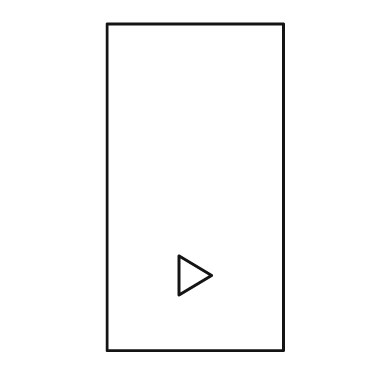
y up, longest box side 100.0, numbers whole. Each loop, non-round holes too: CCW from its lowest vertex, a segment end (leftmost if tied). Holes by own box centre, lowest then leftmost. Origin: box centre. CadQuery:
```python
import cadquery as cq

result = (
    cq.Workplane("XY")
    .moveTo(-27.0, -50.0)
    .lineTo(27.0, -50.0)
    .lineTo(27.0, 50.0)
    .lineTo(-27.0, 50.0)
    .close()
    .moveTo(-5.0, -33.0)
    .lineTo(5.0, -27.0)
    .lineTo(-5.0, -21.0)
    .close()
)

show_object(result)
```